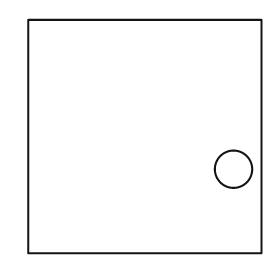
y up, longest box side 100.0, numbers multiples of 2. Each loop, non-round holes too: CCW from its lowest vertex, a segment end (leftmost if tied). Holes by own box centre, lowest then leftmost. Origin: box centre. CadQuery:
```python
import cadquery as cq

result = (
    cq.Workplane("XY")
    .moveTo(-50.0, -50.0)
    .lineTo(50.0, -50.0)
    .lineTo(50.0, 50.0)
    .lineTo(-50.0, 50.0)
    .close()
    .moveTo(38.0, -14.0)
    .circle(8.0)
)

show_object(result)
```